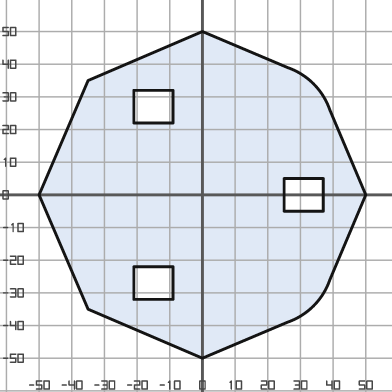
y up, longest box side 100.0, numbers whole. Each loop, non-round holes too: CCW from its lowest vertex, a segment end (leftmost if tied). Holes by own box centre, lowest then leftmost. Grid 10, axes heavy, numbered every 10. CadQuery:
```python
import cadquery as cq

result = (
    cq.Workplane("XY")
    .moveTo(0.0, -50.0)
    .lineTo(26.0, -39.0)
    .threePointArc((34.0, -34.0), (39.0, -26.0))
    .lineTo(50.0, 0.0)
    .lineTo(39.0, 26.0)
    .threePointArc((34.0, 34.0), (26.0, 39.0))
    .lineTo(0.0, 50.0)
    .lineTo(-35.0, 35.0)
    .lineTo(-50.0, 0.0)
    .lineTo(-35.0, -35.0)
    .close()
    .moveTo(-21.0, -32.0)
    .lineTo(-9.0, -32.0)
    .lineTo(-9.0, -22.0)
    .lineTo(-21.0, -22.0)
    .close()
    .moveTo(25.0, -5.0)
    .lineTo(37.0, -5.0)
    .lineTo(37.0, 5.0)
    .lineTo(25.0, 5.0)
    .close()
    .moveTo(-21.0, 22.0)
    .lineTo(-9.0, 22.0)
    .lineTo(-9.0, 32.0)
    .lineTo(-21.0, 32.0)
    .close()
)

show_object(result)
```